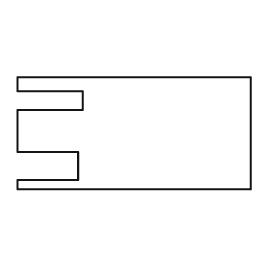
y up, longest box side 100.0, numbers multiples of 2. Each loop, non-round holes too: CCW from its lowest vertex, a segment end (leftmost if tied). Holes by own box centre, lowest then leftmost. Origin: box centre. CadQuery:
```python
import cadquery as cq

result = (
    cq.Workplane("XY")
    .moveTo(-50.0, -24.0)
    .lineTo(50.0, -24.0)
    .lineTo(50.0, 24.0)
    .lineTo(-50.0, 24.0)
    .lineTo(-50.0, 18.0)
    .lineTo(-22.0, 18.0)
    .lineTo(-22.0, 10.0)
    .lineTo(-50.0, 10.0)
    .lineTo(-50.0, -8.0)
    .lineTo(-24.0, -8.0)
    .lineTo(-24.0, -20.0)
    .lineTo(-50.0, -20.0)
    .close()
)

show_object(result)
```